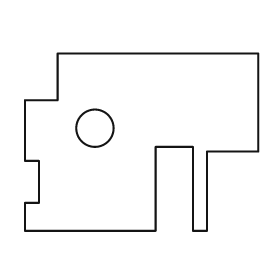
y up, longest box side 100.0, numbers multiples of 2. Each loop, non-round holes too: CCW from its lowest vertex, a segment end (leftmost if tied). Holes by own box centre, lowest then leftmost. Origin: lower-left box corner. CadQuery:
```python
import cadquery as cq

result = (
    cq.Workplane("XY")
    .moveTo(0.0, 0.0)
    .lineTo(56.0, 0.0)
    .lineTo(56.0, 36.0)
    .lineTo(72.0, 36.0)
    .lineTo(72.0, 0.0)
    .lineTo(78.0, 0.0)
    .lineTo(78.0, 34.0)
    .lineTo(100.0, 34.0)
    .lineTo(100.0, 76.0)
    .lineTo(14.0, 76.0)
    .lineTo(14.0, 56.0)
    .lineTo(0.0, 56.0)
    .lineTo(0.0, 30.0)
    .lineTo(6.0, 30.0)
    .lineTo(6.0, 12.0)
    .lineTo(0.0, 12.0)
    .close()
    .moveTo(30.0, 44.0)
    .circle(8.0)
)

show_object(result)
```